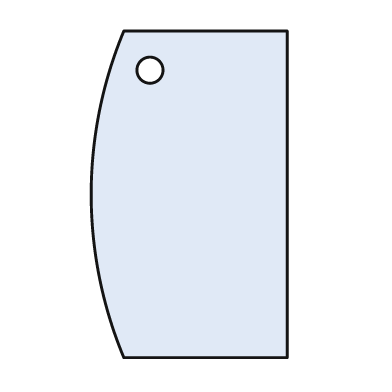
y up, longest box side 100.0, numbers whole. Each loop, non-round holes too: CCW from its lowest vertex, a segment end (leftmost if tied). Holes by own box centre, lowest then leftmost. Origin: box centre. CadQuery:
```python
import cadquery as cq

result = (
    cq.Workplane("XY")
    .moveTo(-20.0, -50.0)
    .lineTo(30.0, -50.0)
    .lineTo(30.0, 50.0)
    .lineTo(-20.0, 50.0)
    .threePointArc((-30.0, 0.0), (-20.0, -50.0))
    .close()
    .moveTo(-12.0, 38.0)
    .circle(4.0)
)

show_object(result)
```